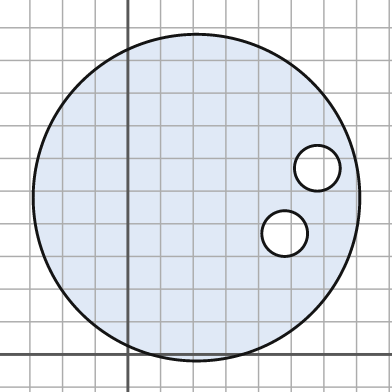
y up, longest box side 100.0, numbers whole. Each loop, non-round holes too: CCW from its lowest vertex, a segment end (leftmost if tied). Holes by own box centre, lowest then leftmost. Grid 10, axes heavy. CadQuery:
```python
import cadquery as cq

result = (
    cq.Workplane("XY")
    .moveTo(21.0, 48.0)
    .circle(50.0)
    .moveTo(48.0, 37.0)
    .circle(7.0)
    .moveTo(58.0, 57.0)
    .circle(7.0)
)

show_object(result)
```